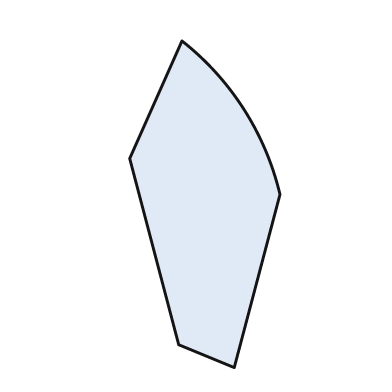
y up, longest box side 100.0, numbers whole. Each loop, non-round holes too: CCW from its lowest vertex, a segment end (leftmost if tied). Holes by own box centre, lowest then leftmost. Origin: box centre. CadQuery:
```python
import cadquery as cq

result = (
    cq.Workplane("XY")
    .moveTo(9.0, -50.0)
    .lineTo(23.0, 3.0)
    .threePointArc((12.0, 29.0), (-7.0, 50.0))
    .lineTo(-23.0, 14.0)
    .lineTo(-8.0, -43.0)
    .close()
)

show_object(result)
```